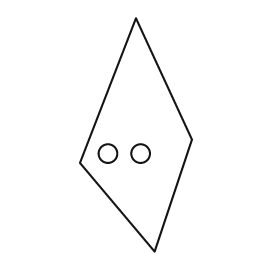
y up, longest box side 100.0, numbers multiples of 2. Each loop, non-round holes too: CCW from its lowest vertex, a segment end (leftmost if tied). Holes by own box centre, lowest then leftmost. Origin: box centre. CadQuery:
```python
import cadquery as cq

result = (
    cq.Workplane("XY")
    .moveTo(8.0, -50.0)
    .lineTo(24.0, -2.0)
    .lineTo(0.0, 50.0)
    .lineTo(-24.0, -12.0)
    .close()
    .moveTo(-12.0, -8.0)
    .circle(4.0)
    .moveTo(2.0, -8.0)
    .circle(4.0)
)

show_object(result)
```